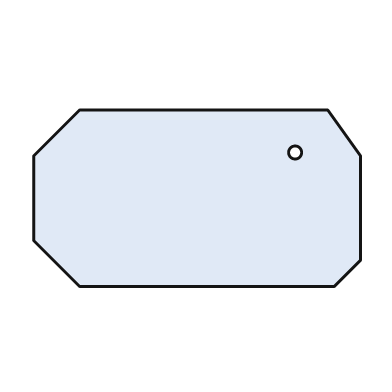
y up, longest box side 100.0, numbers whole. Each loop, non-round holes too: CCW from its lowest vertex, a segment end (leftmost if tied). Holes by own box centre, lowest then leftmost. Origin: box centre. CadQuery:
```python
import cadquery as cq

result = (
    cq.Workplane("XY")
    .moveTo(-36.0, -27.0)
    .lineTo(42.0, -27.0)
    .lineTo(50.0, -19.0)
    .lineTo(50.0, 13.0)
    .lineTo(40.0, 27.0)
    .lineTo(-36.0, 27.0)
    .lineTo(-50.0, 13.0)
    .lineTo(-50.0, -13.0)
    .close()
    .moveTo(30.0, 14.0)
    .circle(2.0)
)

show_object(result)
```